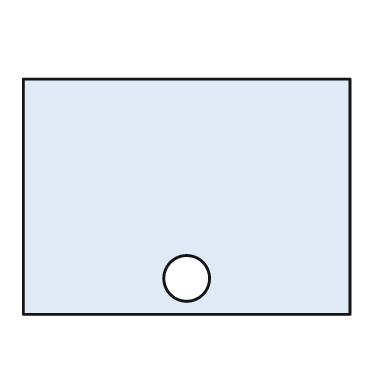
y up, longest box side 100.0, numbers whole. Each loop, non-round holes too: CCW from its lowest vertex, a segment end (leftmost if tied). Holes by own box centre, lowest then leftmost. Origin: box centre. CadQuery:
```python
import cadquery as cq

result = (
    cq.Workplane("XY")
    .moveTo(-50.0, -36.0)
    .lineTo(50.0, -36.0)
    .lineTo(50.0, 36.0)
    .lineTo(-50.0, 36.0)
    .close()
    .moveTo(0.0, -25.0)
    .circle(7.0)
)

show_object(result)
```